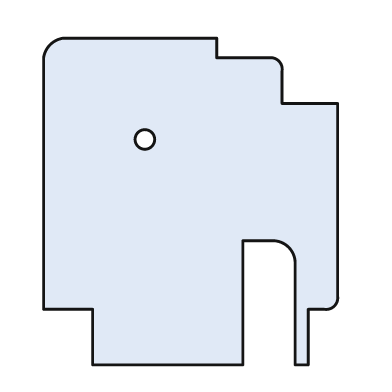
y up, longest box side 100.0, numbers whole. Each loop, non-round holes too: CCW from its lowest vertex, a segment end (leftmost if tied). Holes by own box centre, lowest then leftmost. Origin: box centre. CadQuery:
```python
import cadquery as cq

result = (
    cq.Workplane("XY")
    .moveTo(-30.0, -50.0)
    .lineTo(16.0, -50.0)
    .lineTo(16.0, -12.0)
    .lineTo(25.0, -12.0)
    .threePointArc((30.0, -14.0), (32.0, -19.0))
    .lineTo(32.0, -50.0)
    .lineTo(36.0, -50.0)
    .lineTo(36.0, -33.0)
    .lineTo(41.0, -33.0)
    .threePointArc((44.0, -32.0), (45.0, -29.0))
    .lineTo(45.0, 30.0)
    .lineTo(28.0, 30.0)
    .lineTo(28.0, 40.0)
    .threePointArc((27.0, 43.0), (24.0, 44.0))
    .lineTo(8.0, 44.0)
    .lineTo(8.0, 50.0)
    .lineTo(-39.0, 50.0)
    .threePointArc((-43.0, 48.0), (-45.0, 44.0))
    .lineTo(-45.0, -33.0)
    .lineTo(-30.0, -33.0)
    .close()
    .moveTo(-14.0, 19.0)
    .circle(3.0)
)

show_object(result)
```